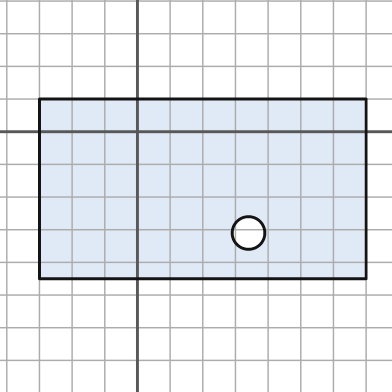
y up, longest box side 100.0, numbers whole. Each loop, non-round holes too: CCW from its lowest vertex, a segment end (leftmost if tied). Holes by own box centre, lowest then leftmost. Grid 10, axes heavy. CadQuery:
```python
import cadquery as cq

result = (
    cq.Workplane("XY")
    .moveTo(-30.0, -45.0)
    .lineTo(70.0, -45.0)
    .lineTo(70.0, 10.0)
    .lineTo(-30.0, 10.0)
    .close()
    .moveTo(34.0, -31.0)
    .circle(5.0)
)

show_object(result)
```